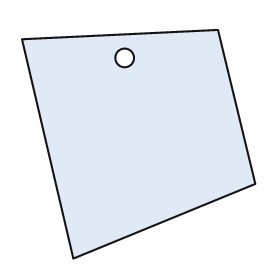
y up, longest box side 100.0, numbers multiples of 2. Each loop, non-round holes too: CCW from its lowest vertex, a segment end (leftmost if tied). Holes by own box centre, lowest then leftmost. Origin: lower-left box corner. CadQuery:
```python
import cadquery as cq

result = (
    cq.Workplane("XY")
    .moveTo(22.0, 0.0)
    .lineTo(100.0, 32.0)
    .lineTo(84.0, 98.0)
    .lineTo(0.0, 94.0)
    .close()
    .moveTo(44.0, 86.0)
    .circle(4.0)
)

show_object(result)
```